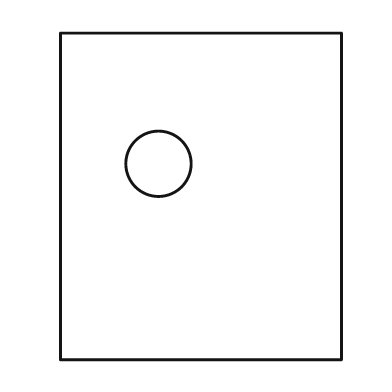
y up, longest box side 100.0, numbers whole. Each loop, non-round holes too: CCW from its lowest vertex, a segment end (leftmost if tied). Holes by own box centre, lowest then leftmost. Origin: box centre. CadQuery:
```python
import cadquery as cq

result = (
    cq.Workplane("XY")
    .moveTo(-43.0, -50.0)
    .lineTo(43.0, -50.0)
    .lineTo(43.0, 50.0)
    .lineTo(-43.0, 50.0)
    .close()
    .moveTo(-13.0, 10.0)
    .circle(10.0)
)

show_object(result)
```